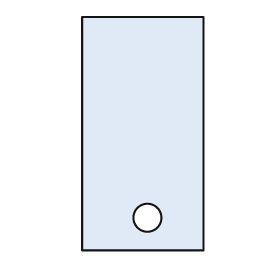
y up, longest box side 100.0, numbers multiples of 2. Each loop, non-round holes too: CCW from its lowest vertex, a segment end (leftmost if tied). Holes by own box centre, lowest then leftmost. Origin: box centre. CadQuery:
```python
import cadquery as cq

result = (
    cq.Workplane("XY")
    .moveTo(-26.0, -50.0)
    .lineTo(26.0, -50.0)
    .lineTo(26.0, 50.0)
    .lineTo(-26.0, 50.0)
    .close()
    .moveTo(2.0, -36.0)
    .circle(6.0)
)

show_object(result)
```